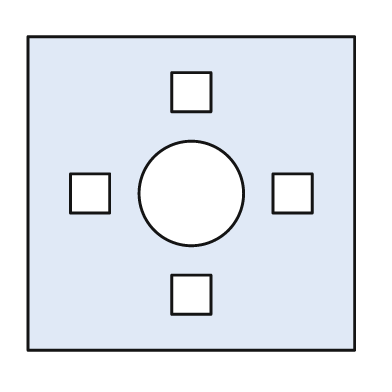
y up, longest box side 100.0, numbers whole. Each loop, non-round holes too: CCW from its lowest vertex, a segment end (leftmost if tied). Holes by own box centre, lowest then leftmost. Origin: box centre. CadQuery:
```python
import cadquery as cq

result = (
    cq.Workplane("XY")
    .moveTo(-50.0, -48.0)
    .lineTo(50.0, -48.0)
    .lineTo(50.0, 48.0)
    .lineTo(-50.0, 48.0)
    .close()
    .moveTo(-6.0, -37.0)
    .lineTo(6.0, -37.0)
    .lineTo(6.0, -25.0)
    .lineTo(-6.0, -25.0)
    .close()
    .moveTo(-37.0, -6.0)
    .lineTo(-25.0, -6.0)
    .lineTo(-25.0, 6.0)
    .lineTo(-37.0, 6.0)
    .close()
    .moveTo(0.0, 0.0)
    .circle(16.0)
    .moveTo(25.0, -6.0)
    .lineTo(37.0, -6.0)
    .lineTo(37.0, 6.0)
    .lineTo(25.0, 6.0)
    .close()
    .moveTo(-6.0, 25.0)
    .lineTo(6.0, 25.0)
    .lineTo(6.0, 37.0)
    .lineTo(-6.0, 37.0)
    .close()
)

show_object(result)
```